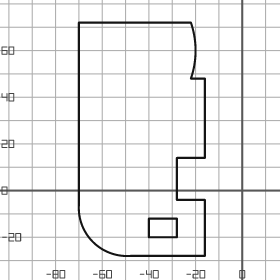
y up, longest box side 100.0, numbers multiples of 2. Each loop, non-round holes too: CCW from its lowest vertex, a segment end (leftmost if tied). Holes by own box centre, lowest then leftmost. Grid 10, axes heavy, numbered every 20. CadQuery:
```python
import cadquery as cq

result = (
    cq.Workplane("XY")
    .moveTo(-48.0, -28.0)
    .lineTo(-16.0, -28.0)
    .lineTo(-16.0, -4.0)
    .lineTo(-28.0, -4.0)
    .lineTo(-28.0, 14.0)
    .lineTo(-16.0, 14.0)
    .lineTo(-16.0, 48.0)
    .lineTo(-22.0, 48.0)
    .threePointArc((-20.0, 60.0), (-22.0, 72.0))
    .lineTo(-70.0, 72.0)
    .lineTo(-70.0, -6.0)
    .threePointArc((-64.0, -22.0), (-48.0, -28.0))
    .close()
    .moveTo(-40.0, -20.0)
    .lineTo(-28.0, -20.0)
    .lineTo(-28.0, -12.0)
    .lineTo(-40.0, -12.0)
    .close()
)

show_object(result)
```